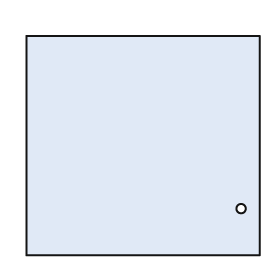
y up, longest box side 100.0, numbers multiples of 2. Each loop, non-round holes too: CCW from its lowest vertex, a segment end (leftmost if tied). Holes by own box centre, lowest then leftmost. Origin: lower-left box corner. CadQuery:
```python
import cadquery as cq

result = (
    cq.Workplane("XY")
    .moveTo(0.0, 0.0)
    .lineTo(100.0, 0.0)
    .lineTo(100.0, 94.0)
    .lineTo(0.0, 94.0)
    .close()
    .moveTo(92.0, 20.0)
    .circle(2.0)
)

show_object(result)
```